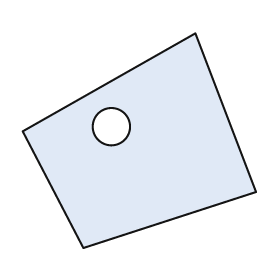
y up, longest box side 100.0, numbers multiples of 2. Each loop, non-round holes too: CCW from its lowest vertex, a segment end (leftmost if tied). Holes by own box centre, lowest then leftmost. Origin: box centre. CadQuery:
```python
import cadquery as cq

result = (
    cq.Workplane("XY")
    .moveTo(-24.0, -46.0)
    .lineTo(50.0, -22.0)
    .lineTo(24.0, 46.0)
    .lineTo(-50.0, 4.0)
    .close()
    .moveTo(-12.0, 6.0)
    .circle(8.0)
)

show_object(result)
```